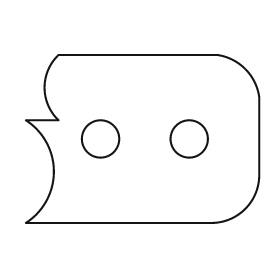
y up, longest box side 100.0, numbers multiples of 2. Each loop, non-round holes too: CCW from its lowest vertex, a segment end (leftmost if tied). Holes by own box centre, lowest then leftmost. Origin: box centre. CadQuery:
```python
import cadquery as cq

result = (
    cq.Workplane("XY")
    .moveTo(-50.0, -36.0)
    .lineTo(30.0, -36.0)
    .threePointArc((44.0, -30.0), (50.0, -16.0))
    .lineTo(50.0, 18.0)
    .threePointArc((44.0, 30.0), (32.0, 36.0))
    .lineTo(-36.0, 36.0)
    .threePointArc((-42.0, 22.0), (-36.0, 8.0))
    .lineTo(-50.0, 8.0)
    .threePointArc((-38.0, -14.0), (-50.0, -36.0))
    .close()
    .moveTo(-18.0, 0.0)
    .circle(8.0)
    .moveTo(20.0, 0.0)
    .circle(8.0)
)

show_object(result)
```